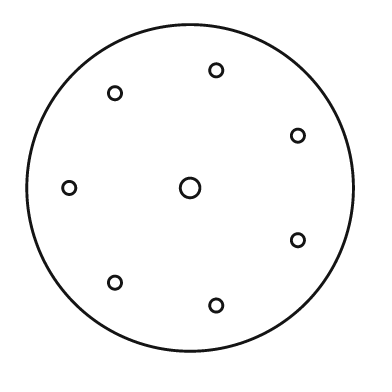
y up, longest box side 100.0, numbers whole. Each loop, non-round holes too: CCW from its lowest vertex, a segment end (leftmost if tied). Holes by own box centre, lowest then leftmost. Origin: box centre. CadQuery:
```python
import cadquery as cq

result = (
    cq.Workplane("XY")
    .moveTo(0.0, 0.0)
    .circle(50.0)
    .moveTo(8.0, -36.0)
    .circle(2.0)
    .moveTo(-23.0, -29.0)
    .circle(2.0)
    .moveTo(33.0, -16.0)
    .circle(2.0)
    .moveTo(-37.0, 0.0)
    .circle(2.0)
    .moveTo(0.0, 0.0)
    .circle(3.0)
    .moveTo(33.0, 16.0)
    .circle(2.0)
    .moveTo(-23.0, 29.0)
    .circle(2.0)
    .moveTo(8.0, 36.0)
    .circle(2.0)
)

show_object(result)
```